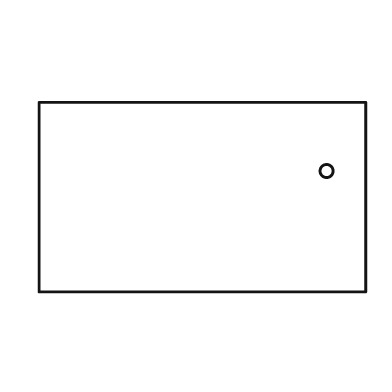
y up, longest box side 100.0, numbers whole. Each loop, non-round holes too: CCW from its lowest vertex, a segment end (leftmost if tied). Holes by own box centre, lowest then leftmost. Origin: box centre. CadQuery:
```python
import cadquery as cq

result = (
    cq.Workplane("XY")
    .moveTo(-50.0, -29.0)
    .lineTo(50.0, -29.0)
    .lineTo(50.0, 29.0)
    .lineTo(-50.0, 29.0)
    .close()
    .moveTo(38.0, 8.0)
    .circle(2.0)
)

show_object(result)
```